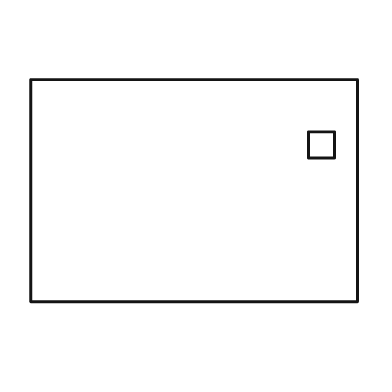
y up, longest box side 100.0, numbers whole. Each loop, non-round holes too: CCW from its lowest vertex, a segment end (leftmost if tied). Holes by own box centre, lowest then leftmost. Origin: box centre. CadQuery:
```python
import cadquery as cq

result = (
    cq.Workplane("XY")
    .moveTo(-50.0, -34.0)
    .lineTo(50.0, -34.0)
    .lineTo(50.0, 34.0)
    .lineTo(-50.0, 34.0)
    .close()
    .moveTo(35.0, 10.0)
    .lineTo(43.0, 10.0)
    .lineTo(43.0, 18.0)
    .lineTo(35.0, 18.0)
    .close()
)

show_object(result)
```